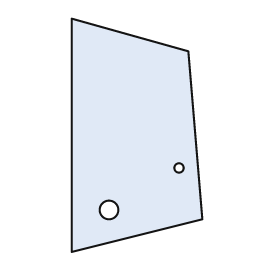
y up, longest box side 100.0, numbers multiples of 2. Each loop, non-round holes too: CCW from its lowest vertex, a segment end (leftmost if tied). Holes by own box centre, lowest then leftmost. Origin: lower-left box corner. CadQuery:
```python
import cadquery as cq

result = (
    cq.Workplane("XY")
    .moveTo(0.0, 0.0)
    .lineTo(56.0, 14.0)
    .lineTo(50.0, 86.0)
    .lineTo(0.0, 100.0)
    .close()
    .moveTo(16.0, 18.0)
    .circle(4.0)
    .moveTo(46.0, 36.0)
    .circle(2.0)
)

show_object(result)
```